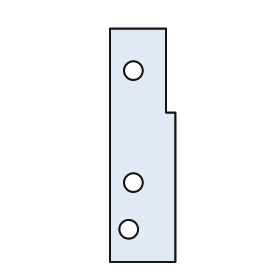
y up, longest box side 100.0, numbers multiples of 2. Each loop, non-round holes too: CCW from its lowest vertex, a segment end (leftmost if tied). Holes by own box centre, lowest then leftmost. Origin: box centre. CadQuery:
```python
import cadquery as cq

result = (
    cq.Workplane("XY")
    .moveTo(-14.0, -50.0)
    .lineTo(14.0, -50.0)
    .lineTo(14.0, 14.0)
    .lineTo(10.0, 14.0)
    .lineTo(10.0, 50.0)
    .lineTo(-14.0, 50.0)
    .close()
    .moveTo(-6.0, -36.0)
    .circle(4.0)
    .moveTo(-4.0, -16.0)
    .circle(4.0)
    .moveTo(-4.0, 32.0)
    .circle(4.0)
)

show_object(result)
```